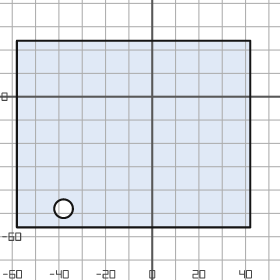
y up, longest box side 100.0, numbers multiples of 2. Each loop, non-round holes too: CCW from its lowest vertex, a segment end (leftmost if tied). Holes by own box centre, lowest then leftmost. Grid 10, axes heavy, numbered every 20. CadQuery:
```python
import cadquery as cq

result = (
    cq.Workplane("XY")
    .moveTo(-58.0, -56.0)
    .lineTo(42.0, -56.0)
    .lineTo(42.0, 24.0)
    .lineTo(-58.0, 24.0)
    .close()
    .moveTo(-38.0, -48.0)
    .circle(4.0)
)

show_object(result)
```